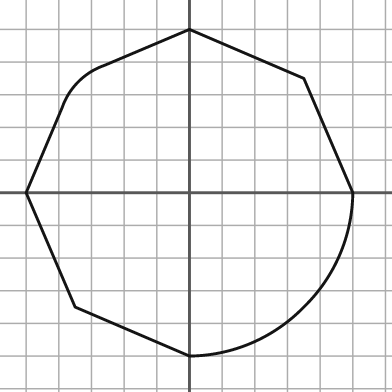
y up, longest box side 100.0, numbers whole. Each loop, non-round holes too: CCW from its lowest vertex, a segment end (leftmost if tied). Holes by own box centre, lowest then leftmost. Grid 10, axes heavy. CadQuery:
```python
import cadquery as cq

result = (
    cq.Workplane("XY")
    .moveTo(0.0, -50.0)
    .threePointArc((19.0, -46.0), (35.0, -35.0))
    .threePointArc((46.0, -19.0), (50.0, 0.0))
    .lineTo(35.0, 35.0)
    .lineTo(0.0, 50.0)
    .lineTo(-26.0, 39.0)
    .threePointArc((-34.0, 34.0), (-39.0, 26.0))
    .lineTo(-50.0, 0.0)
    .lineTo(-35.0, -35.0)
    .close()
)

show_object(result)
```